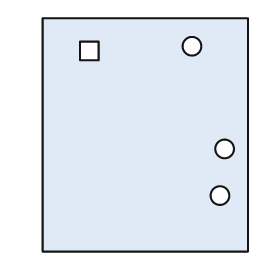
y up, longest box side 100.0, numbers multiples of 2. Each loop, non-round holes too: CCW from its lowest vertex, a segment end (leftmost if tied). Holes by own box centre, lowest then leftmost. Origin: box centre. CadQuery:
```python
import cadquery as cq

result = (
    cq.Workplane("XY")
    .moveTo(-44.0, -50.0)
    .lineTo(44.0, -50.0)
    .lineTo(44.0, 50.0)
    .lineTo(-44.0, 50.0)
    .close()
    .moveTo(32.0, -26.0)
    .circle(4.0)
    .moveTo(34.0, -6.0)
    .circle(4.0)
    .moveTo(-28.0, 32.0)
    .lineTo(-20.0, 32.0)
    .lineTo(-20.0, 40.0)
    .lineTo(-28.0, 40.0)
    .close()
    .moveTo(20.0, 38.0)
    .circle(4.0)
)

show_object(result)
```